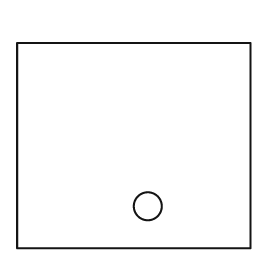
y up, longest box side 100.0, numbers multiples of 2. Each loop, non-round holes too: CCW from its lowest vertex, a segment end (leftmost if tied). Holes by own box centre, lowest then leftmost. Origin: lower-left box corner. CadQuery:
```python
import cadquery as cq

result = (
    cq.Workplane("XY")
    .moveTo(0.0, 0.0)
    .lineTo(100.0, 0.0)
    .lineTo(100.0, 88.0)
    .lineTo(0.0, 88.0)
    .close()
    .moveTo(56.0, 18.0)
    .circle(6.0)
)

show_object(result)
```